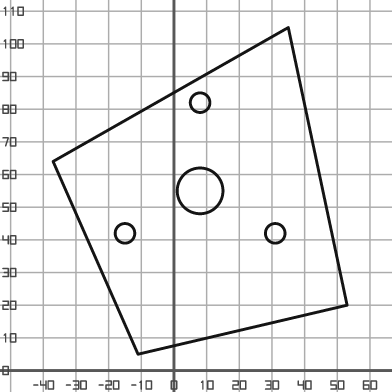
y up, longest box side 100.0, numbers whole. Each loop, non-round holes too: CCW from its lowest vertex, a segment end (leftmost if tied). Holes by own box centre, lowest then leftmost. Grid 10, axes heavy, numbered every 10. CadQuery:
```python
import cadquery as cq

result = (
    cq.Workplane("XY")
    .moveTo(-11.0, 5.0)
    .lineTo(53.0, 20.0)
    .lineTo(35.0, 105.0)
    .lineTo(-37.0, 64.0)
    .close()
    .moveTo(-15.0, 42.0)
    .circle(3.0)
    .moveTo(31.0, 42.0)
    .circle(3.0)
    .moveTo(8.0, 55.0)
    .circle(7.0)
    .moveTo(8.0, 82.0)
    .circle(3.0)
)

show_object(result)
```